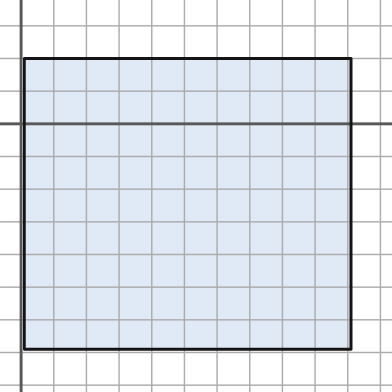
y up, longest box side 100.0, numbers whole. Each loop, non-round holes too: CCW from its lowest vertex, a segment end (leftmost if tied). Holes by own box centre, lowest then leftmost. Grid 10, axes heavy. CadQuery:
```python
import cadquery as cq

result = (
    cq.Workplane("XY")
    .moveTo(1.0, -69.0)
    .lineTo(101.0, -69.0)
    .lineTo(101.0, 20.0)
    .lineTo(1.0, 20.0)
    .close()
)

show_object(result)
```